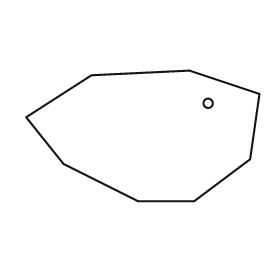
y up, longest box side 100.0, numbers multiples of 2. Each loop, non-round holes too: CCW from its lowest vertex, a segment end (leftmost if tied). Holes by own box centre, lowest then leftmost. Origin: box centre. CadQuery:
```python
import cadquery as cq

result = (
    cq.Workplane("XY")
    .moveTo(-2.0, -28.0)
    .lineTo(22.0, -28.0)
    .lineTo(46.0, -10.0)
    .lineTo(50.0, 18.0)
    .lineTo(20.0, 28.0)
    .lineTo(-22.0, 26.0)
    .lineTo(-50.0, 8.0)
    .lineTo(-34.0, -12.0)
    .close()
    .moveTo(28.0, 14.0)
    .circle(2.0)
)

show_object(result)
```